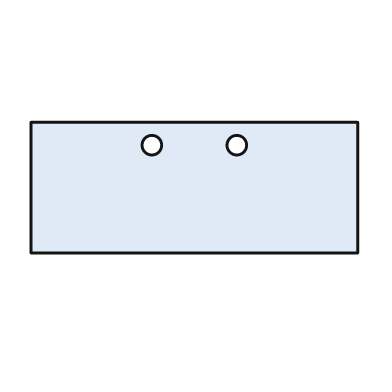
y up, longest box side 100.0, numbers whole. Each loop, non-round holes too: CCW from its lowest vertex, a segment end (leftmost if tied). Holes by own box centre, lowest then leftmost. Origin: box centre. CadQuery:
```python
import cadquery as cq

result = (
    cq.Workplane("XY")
    .moveTo(-50.0, -20.0)
    .lineTo(50.0, -20.0)
    .lineTo(50.0, 20.0)
    .lineTo(-50.0, 20.0)
    .close()
    .moveTo(-13.0, 13.0)
    .circle(3.0)
    .moveTo(13.0, 13.0)
    .circle(3.0)
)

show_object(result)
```